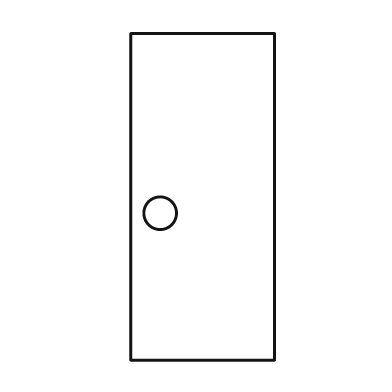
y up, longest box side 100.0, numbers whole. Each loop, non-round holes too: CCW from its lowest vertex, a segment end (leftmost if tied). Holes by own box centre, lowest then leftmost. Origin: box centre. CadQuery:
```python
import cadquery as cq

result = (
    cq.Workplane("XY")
    .moveTo(-22.0, -50.0)
    .lineTo(22.0, -50.0)
    .lineTo(22.0, 50.0)
    .lineTo(-22.0, 50.0)
    .close()
    .moveTo(-13.0, -5.0)
    .circle(5.0)
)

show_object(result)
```